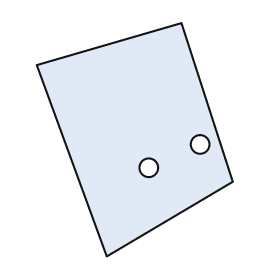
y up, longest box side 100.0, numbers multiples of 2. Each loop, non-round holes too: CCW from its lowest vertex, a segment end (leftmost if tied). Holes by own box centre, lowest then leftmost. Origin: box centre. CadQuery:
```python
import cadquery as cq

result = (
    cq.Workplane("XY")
    .moveTo(-12.0, -50.0)
    .lineTo(42.0, -18.0)
    .lineTo(20.0, 50.0)
    .lineTo(-42.0, 32.0)
    .close()
    .moveTo(6.0, -12.0)
    .circle(4.0)
    .moveTo(28.0, -2.0)
    .circle(4.0)
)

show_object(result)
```